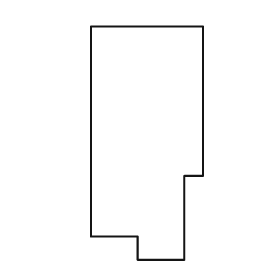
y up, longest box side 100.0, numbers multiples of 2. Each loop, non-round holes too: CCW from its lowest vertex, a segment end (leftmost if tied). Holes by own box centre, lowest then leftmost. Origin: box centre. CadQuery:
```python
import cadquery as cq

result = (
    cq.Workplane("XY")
    .moveTo(-4.0, -50.0)
    .lineTo(16.0, -50.0)
    .lineTo(16.0, -14.0)
    .lineTo(24.0, -14.0)
    .lineTo(24.0, 50.0)
    .lineTo(-24.0, 50.0)
    .lineTo(-24.0, -40.0)
    .lineTo(-4.0, -40.0)
    .close()
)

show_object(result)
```